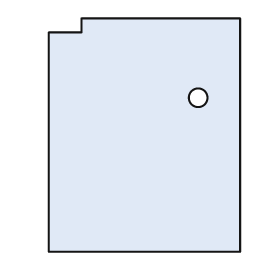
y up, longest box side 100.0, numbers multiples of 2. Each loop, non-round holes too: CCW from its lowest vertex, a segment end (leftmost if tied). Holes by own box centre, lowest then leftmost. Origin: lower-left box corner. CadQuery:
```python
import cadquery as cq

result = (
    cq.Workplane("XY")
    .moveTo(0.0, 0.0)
    .lineTo(82.0, 0.0)
    .lineTo(82.0, 100.0)
    .lineTo(14.0, 100.0)
    .lineTo(14.0, 94.0)
    .lineTo(0.0, 94.0)
    .close()
    .moveTo(64.0, 66.0)
    .circle(4.0)
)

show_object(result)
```